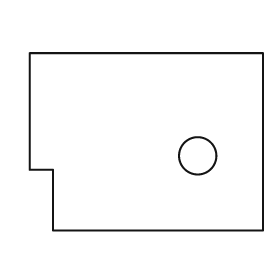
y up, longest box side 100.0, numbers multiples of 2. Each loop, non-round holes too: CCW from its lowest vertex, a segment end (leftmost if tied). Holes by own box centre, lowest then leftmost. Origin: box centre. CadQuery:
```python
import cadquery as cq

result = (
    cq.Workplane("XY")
    .moveTo(-40.0, -38.0)
    .lineTo(50.0, -38.0)
    .lineTo(50.0, 38.0)
    .lineTo(-50.0, 38.0)
    .lineTo(-50.0, -12.0)
    .lineTo(-40.0, -12.0)
    .close()
    .moveTo(22.0, -6.0)
    .circle(8.0)
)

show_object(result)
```